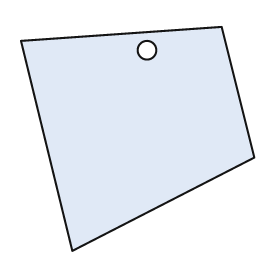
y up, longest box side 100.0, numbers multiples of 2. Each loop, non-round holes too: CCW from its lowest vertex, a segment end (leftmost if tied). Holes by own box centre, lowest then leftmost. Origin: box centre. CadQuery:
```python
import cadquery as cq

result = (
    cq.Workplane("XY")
    .moveTo(-28.0, -48.0)
    .lineTo(50.0, -8.0)
    .lineTo(36.0, 48.0)
    .lineTo(-50.0, 42.0)
    .close()
    .moveTo(4.0, 38.0)
    .circle(4.0)
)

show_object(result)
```